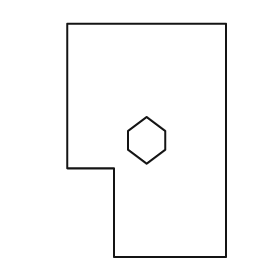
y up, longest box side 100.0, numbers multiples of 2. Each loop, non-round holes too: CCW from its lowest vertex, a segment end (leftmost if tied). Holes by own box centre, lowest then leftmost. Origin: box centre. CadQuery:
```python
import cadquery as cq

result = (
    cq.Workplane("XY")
    .moveTo(-14.0, -50.0)
    .lineTo(34.0, -50.0)
    .lineTo(34.0, 50.0)
    .lineTo(-34.0, 50.0)
    .lineTo(-34.0, -12.0)
    .lineTo(-14.0, -12.0)
    .close()
    .moveTo(0.0, -10.0)
    .lineTo(8.0, -4.0)
    .lineTo(8.0, 4.0)
    .lineTo(0.0, 10.0)
    .lineTo(-8.0, 4.0)
    .lineTo(-8.0, -4.0)
    .close()
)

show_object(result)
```